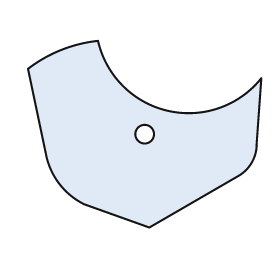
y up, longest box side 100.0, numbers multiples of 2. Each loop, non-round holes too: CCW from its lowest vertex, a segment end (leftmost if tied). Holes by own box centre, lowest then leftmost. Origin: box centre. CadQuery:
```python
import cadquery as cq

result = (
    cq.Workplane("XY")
    .moveTo(2.0, -40.0)
    .lineTo(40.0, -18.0)
    .threePointArc((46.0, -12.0), (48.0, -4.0))
    .lineTo(50.0, 24.0)
    .threePointArc((10.0, 10.0), (-20.0, 40.0))
    .threePointArc((-36.0, 36.0), (-50.0, 28.0))
    .lineTo(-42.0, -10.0)
    .threePointArc((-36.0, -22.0), (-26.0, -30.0))
    .close()
    .moveTo(0.0, 0.0)
    .circle(4.0)
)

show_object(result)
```